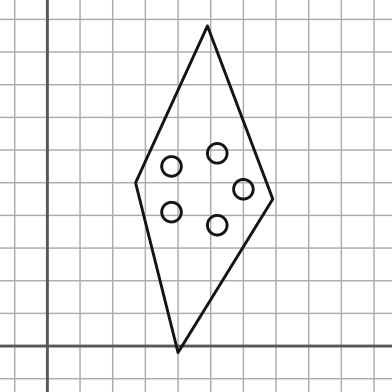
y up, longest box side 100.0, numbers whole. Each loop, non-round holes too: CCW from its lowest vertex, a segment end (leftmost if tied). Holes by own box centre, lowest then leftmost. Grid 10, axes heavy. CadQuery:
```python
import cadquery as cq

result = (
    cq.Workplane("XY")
    .moveTo(40.0, -2.0)
    .lineTo(69.0, 45.0)
    .lineTo(49.0, 98.0)
    .lineTo(27.0, 50.0)
    .close()
    .moveTo(52.0, 37.0)
    .circle(3.0)
    .moveTo(38.0, 41.0)
    .circle(3.0)
    .moveTo(60.0, 48.0)
    .circle(3.0)
    .moveTo(38.0, 55.0)
    .circle(3.0)
    .moveTo(52.0, 59.0)
    .circle(3.0)
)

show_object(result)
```